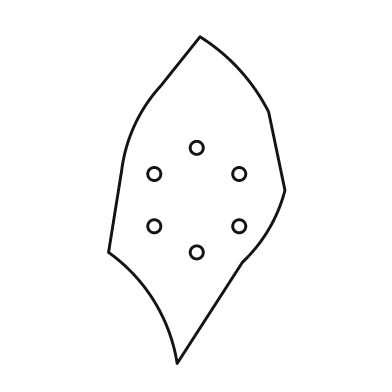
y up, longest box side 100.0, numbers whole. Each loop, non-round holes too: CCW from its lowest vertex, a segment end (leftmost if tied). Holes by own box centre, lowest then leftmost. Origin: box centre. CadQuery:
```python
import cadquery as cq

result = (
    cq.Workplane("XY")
    .moveTo(-6.0, -50.0)
    .lineTo(14.0, -19.0)
    .threePointArc((22.0, -9.0), (27.0, 3.0))
    .lineTo(22.0, 27.0)
    .threePointArc((13.0, 40.0), (1.0, 50.0))
    .lineTo(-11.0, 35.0)
    .threePointArc((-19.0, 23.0), (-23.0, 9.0))
    .lineTo(-27.0, -16.0)
    .threePointArc((-13.0, -31.0), (-6.0, -50.0))
    .close()
    .moveTo(0.0, -16.0)
    .circle(2.0)
    .moveTo(-13.0, -8.0)
    .circle(2.0)
    .moveTo(13.0, -8.0)
    .circle(2.0)
    .moveTo(-13.0, 8.0)
    .circle(2.0)
    .moveTo(13.0, 8.0)
    .circle(2.0)
    .moveTo(0.0, 16.0)
    .circle(2.0)
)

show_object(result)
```